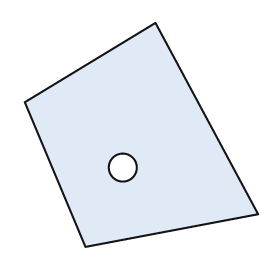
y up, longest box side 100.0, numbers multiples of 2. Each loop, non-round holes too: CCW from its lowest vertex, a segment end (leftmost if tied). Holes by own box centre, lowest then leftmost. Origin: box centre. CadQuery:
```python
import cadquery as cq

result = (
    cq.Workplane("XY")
    .moveTo(-24.0, -48.0)
    .lineTo(50.0, -34.0)
    .lineTo(6.0, 48.0)
    .lineTo(-50.0, 14.0)
    .close()
    .moveTo(-8.0, -14.0)
    .circle(6.0)
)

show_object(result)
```